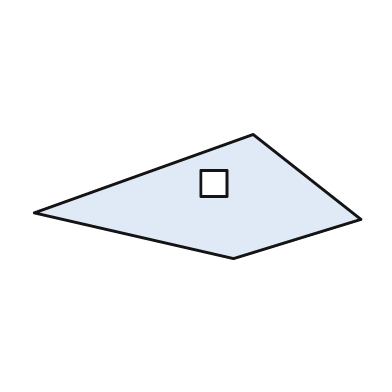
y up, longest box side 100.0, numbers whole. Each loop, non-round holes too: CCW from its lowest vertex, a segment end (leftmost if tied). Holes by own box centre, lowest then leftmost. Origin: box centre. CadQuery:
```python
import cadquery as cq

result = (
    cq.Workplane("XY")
    .moveTo(11.0, -19.0)
    .lineTo(50.0, -7.0)
    .lineTo(17.0, 19.0)
    .lineTo(-50.0, -5.0)
    .close()
    .moveTo(1.0, 0.0)
    .lineTo(9.0, 0.0)
    .lineTo(9.0, 8.0)
    .lineTo(1.0, 8.0)
    .close()
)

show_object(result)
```